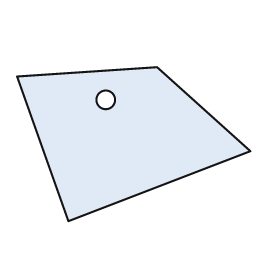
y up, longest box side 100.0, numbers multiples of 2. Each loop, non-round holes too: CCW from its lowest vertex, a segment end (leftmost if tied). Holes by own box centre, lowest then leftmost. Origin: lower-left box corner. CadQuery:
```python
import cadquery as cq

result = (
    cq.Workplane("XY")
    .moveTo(22.0, 0.0)
    .lineTo(100.0, 30.0)
    .lineTo(60.0, 66.0)
    .lineTo(0.0, 62.0)
    .close()
    .moveTo(38.0, 52.0)
    .circle(4.0)
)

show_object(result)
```